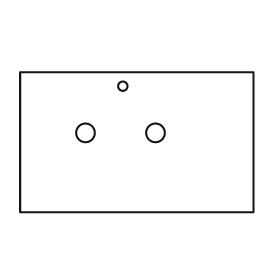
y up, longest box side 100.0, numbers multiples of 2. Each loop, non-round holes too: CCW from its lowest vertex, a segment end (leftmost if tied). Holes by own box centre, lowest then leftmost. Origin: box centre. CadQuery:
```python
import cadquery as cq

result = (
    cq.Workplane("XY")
    .moveTo(-50.0, -30.0)
    .lineTo(50.0, -30.0)
    .lineTo(50.0, 30.0)
    .lineTo(-50.0, 30.0)
    .close()
    .moveTo(-22.0, 4.0)
    .circle(4.0)
    .moveTo(8.0, 4.0)
    .circle(4.0)
    .moveTo(-6.0, 24.0)
    .circle(2.0)
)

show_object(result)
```